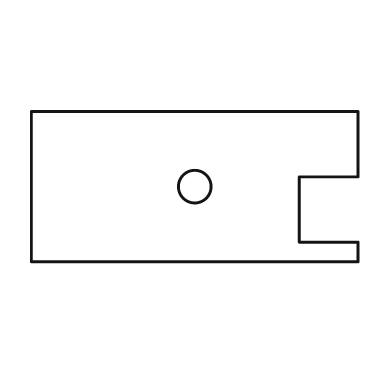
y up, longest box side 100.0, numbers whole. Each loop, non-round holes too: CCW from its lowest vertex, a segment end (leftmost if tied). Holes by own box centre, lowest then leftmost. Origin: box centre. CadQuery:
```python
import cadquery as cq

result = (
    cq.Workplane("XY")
    .moveTo(-50.0, -23.0)
    .lineTo(50.0, -23.0)
    .lineTo(50.0, -17.0)
    .lineTo(32.0, -17.0)
    .lineTo(32.0, 3.0)
    .lineTo(50.0, 3.0)
    .lineTo(50.0, 23.0)
    .lineTo(-50.0, 23.0)
    .close()
    .moveTo(0.0, 0.0)
    .circle(5.0)
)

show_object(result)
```